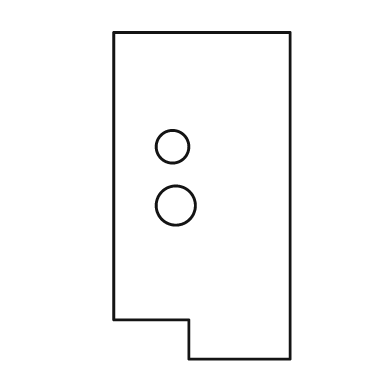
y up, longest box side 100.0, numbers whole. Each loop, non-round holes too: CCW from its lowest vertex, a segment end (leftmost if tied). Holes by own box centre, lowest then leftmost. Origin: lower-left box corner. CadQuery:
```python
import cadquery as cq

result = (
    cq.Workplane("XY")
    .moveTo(23.0, 0.0)
    .lineTo(54.0, 0.0)
    .lineTo(54.0, 100.0)
    .lineTo(0.0, 100.0)
    .lineTo(0.0, 12.0)
    .lineTo(23.0, 12.0)
    .close()
    .moveTo(19.0, 47.0)
    .circle(6.0)
    .moveTo(18.0, 65.0)
    .circle(5.0)
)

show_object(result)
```